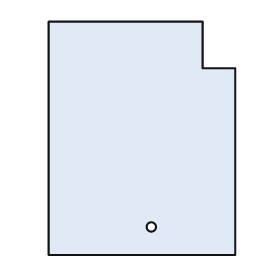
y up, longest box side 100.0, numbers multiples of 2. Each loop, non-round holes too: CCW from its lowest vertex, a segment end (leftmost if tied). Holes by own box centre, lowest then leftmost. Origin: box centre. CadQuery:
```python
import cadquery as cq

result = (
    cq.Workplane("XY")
    .moveTo(-40.0, -50.0)
    .lineTo(40.0, -50.0)
    .lineTo(40.0, 30.0)
    .lineTo(26.0, 30.0)
    .lineTo(26.0, 50.0)
    .lineTo(-40.0, 50.0)
    .close()
    .moveTo(4.0, -38.0)
    .circle(2.0)
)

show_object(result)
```